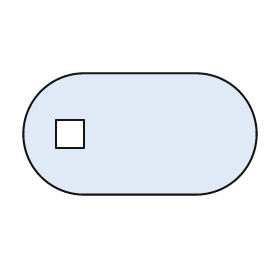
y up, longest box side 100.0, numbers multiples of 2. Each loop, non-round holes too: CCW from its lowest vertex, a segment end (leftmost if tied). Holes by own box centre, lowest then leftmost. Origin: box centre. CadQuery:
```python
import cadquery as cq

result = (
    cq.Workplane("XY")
    .moveTo(-24.0, -26.0)
    .lineTo(24.0, -26.0)
    .threePointArc((50.0, 0.0), (24.0, 26.0))
    .lineTo(-24.0, 26.0)
    .threePointArc((-50.0, 0.0), (-24.0, -26.0))
    .close()
    .moveTo(-36.0, -6.0)
    .lineTo(-24.0, -6.0)
    .lineTo(-24.0, 6.0)
    .lineTo(-36.0, 6.0)
    .close()
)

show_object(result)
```